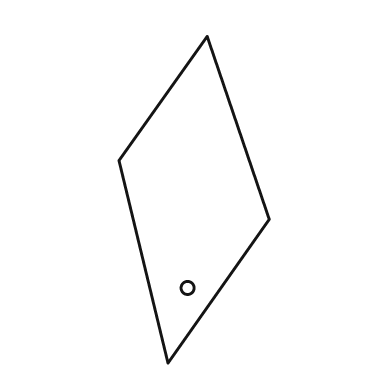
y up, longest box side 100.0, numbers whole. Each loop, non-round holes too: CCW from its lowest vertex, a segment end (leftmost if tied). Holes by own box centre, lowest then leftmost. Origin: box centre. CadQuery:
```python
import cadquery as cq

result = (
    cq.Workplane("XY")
    .moveTo(-8.0, -50.0)
    .lineTo(23.0, -6.0)
    .lineTo(4.0, 50.0)
    .lineTo(-23.0, 12.0)
    .close()
    .moveTo(-2.0, -27.0)
    .circle(2.0)
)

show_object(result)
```